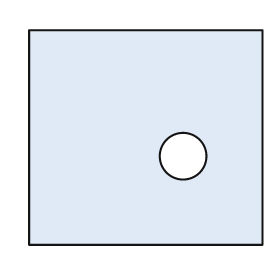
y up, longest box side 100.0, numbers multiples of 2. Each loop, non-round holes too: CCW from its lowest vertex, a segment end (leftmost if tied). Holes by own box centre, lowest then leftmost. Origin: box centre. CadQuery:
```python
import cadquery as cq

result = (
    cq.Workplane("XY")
    .moveTo(-50.0, -46.0)
    .lineTo(50.0, -46.0)
    .lineTo(50.0, 46.0)
    .lineTo(-50.0, 46.0)
    .close()
    .moveTo(16.0, -8.0)
    .circle(10.0)
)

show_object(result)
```